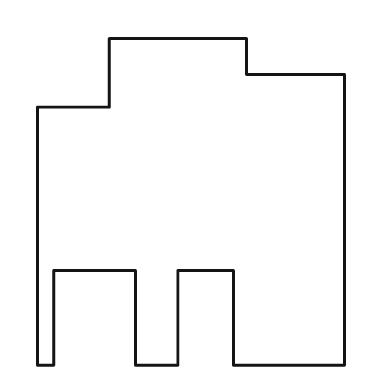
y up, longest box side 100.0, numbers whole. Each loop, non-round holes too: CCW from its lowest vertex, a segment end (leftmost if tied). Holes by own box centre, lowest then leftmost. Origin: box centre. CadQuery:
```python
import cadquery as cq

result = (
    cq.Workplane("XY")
    .moveTo(-47.0, -50.0)
    .lineTo(-42.0, -50.0)
    .lineTo(-42.0, -21.0)
    .lineTo(-17.0, -21.0)
    .lineTo(-17.0, -50.0)
    .lineTo(-4.0, -50.0)
    .lineTo(-4.0, -21.0)
    .lineTo(13.0, -21.0)
    .lineTo(13.0, -50.0)
    .lineTo(47.0, -50.0)
    .lineTo(47.0, 39.0)
    .lineTo(17.0, 39.0)
    .lineTo(17.0, 50.0)
    .lineTo(-25.0, 50.0)
    .lineTo(-25.0, 29.0)
    .lineTo(-47.0, 29.0)
    .close()
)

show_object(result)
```